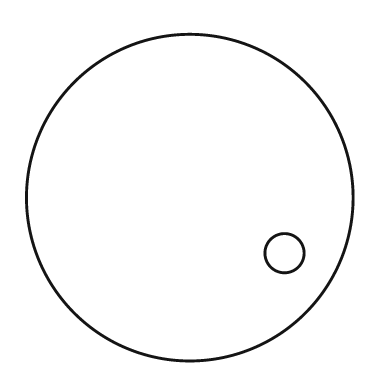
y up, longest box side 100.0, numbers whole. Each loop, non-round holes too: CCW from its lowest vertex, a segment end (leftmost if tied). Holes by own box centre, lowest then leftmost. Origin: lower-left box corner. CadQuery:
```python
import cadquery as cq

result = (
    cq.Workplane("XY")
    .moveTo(50.0, 50.0)
    .circle(50.0)
    .moveTo(79.0, 33.0)
    .circle(6.0)
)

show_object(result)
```